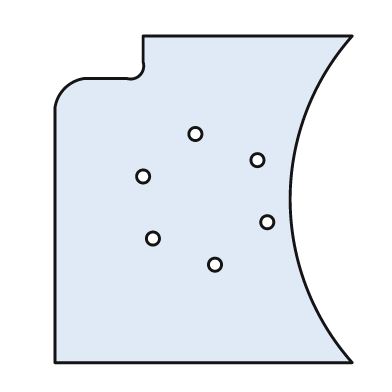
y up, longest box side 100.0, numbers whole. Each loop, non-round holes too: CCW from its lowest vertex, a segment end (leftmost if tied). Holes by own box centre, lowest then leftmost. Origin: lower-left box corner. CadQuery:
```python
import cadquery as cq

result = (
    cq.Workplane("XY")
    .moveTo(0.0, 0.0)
    .lineTo(91.0, 0.0)
    .threePointArc((72.0, 50.0), (91.0, 100.0))
    .lineTo(27.0, 100.0)
    .lineTo(27.0, 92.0)
    .threePointArc((26.0, 88.0), (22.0, 87.0))
    .lineTo(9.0, 87.0)
    .threePointArc((3.0, 84.0), (0.0, 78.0))
    .close()
    .moveTo(49.0, 30.0)
    .circle(2.0)
    .moveTo(30.0, 38.0)
    .circle(2.0)
    .moveTo(65.0, 43.0)
    .circle(2.0)
    .moveTo(27.0, 57.0)
    .circle(2.0)
    .moveTo(62.0, 62.0)
    .circle(2.0)
    .moveTo(43.0, 70.0)
    .circle(2.0)
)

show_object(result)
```